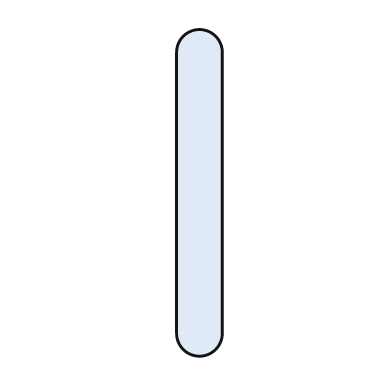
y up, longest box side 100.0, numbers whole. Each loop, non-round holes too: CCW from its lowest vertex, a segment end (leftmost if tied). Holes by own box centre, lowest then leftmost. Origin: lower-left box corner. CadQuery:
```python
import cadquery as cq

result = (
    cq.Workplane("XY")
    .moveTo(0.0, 7.0)
    .threePointArc((7.0, 0.0), (14.0, 7.0))
    .lineTo(14.0, 93.0)
    .threePointArc((7.0, 100.0), (0.0, 93.0))
    .close()
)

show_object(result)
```